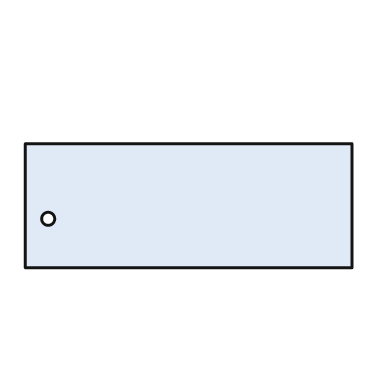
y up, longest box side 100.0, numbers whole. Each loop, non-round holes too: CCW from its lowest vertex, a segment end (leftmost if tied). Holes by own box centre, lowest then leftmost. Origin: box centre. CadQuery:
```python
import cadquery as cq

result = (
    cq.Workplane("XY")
    .moveTo(-50.0, -19.0)
    .lineTo(50.0, -19.0)
    .lineTo(50.0, 19.0)
    .lineTo(-50.0, 19.0)
    .close()
    .moveTo(-43.0, -4.0)
    .circle(2.0)
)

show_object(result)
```